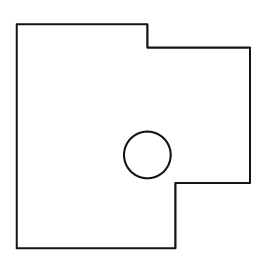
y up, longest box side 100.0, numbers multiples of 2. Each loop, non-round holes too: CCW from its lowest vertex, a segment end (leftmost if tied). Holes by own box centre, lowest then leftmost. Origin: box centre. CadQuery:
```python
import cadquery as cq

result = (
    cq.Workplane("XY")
    .moveTo(-50.0, -48.0)
    .lineTo(18.0, -48.0)
    .lineTo(18.0, -20.0)
    .lineTo(50.0, -20.0)
    .lineTo(50.0, 38.0)
    .lineTo(6.0, 38.0)
    .lineTo(6.0, 48.0)
    .lineTo(-50.0, 48.0)
    .close()
    .moveTo(6.0, -8.0)
    .circle(10.0)
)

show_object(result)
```